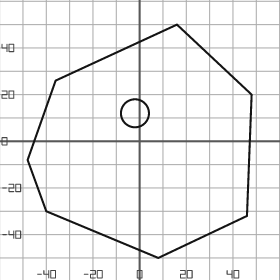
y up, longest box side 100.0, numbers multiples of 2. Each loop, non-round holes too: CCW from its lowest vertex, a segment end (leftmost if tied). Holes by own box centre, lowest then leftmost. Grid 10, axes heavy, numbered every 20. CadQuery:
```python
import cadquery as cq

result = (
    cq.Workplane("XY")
    .moveTo(8.0, -50.0)
    .lineTo(46.0, -32.0)
    .lineTo(48.0, 20.0)
    .lineTo(16.0, 50.0)
    .lineTo(-36.0, 26.0)
    .lineTo(-48.0, -8.0)
    .lineTo(-40.0, -30.0)
    .close()
    .moveTo(-2.0, 12.0)
    .circle(6.0)
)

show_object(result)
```